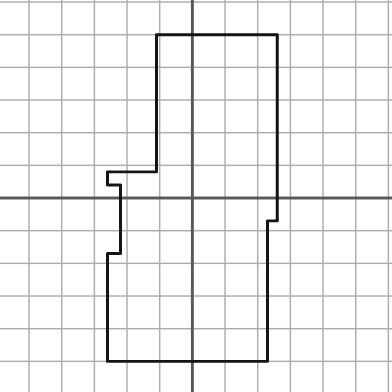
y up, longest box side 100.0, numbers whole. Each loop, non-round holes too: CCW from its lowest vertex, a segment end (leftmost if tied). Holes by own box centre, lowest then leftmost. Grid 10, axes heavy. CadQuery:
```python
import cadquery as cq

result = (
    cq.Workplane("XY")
    .moveTo(-26.0, -50.0)
    .lineTo(23.0, -50.0)
    .lineTo(23.0, -7.0)
    .lineTo(26.0, -7.0)
    .lineTo(26.0, 50.0)
    .lineTo(-11.0, 50.0)
    .lineTo(-11.0, 8.0)
    .lineTo(-26.0, 8.0)
    .lineTo(-26.0, 4.0)
    .lineTo(-22.0, 4.0)
    .lineTo(-22.0, -17.0)
    .lineTo(-26.0, -17.0)
    .close()
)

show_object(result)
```